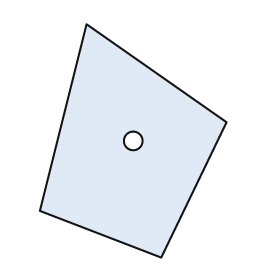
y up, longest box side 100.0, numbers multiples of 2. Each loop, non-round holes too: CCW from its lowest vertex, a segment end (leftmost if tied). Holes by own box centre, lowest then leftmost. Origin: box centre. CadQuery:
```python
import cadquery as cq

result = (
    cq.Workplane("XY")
    .moveTo(12.0, -50.0)
    .lineTo(40.0, 8.0)
    .lineTo(-20.0, 50.0)
    .lineTo(-40.0, -30.0)
    .close()
    .moveTo(0.0, 0.0)
    .circle(4.0)
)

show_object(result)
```